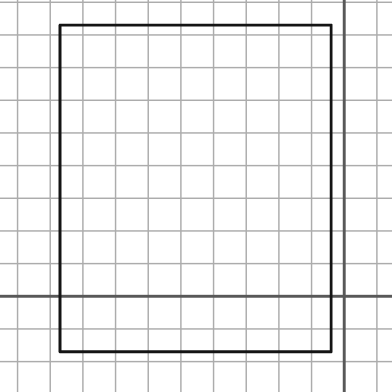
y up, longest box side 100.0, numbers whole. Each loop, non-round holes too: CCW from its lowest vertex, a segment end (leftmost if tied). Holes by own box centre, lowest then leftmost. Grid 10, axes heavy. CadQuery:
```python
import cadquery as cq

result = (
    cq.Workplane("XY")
    .moveTo(-87.0, -17.0)
    .lineTo(-4.0, -17.0)
    .lineTo(-4.0, 83.0)
    .lineTo(-87.0, 83.0)
    .close()
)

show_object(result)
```